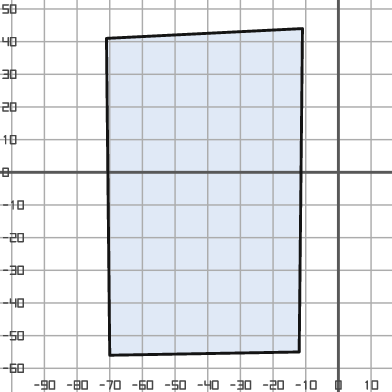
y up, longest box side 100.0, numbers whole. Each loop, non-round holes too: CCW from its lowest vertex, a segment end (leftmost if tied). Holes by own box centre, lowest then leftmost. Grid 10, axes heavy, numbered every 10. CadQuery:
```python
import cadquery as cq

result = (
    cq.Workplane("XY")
    .moveTo(-70.0, -56.0)
    .lineTo(-12.0, -55.0)
    .lineTo(-11.0, 44.0)
    .lineTo(-71.0, 41.0)
    .close()
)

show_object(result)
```